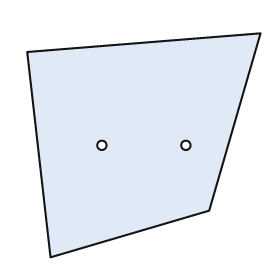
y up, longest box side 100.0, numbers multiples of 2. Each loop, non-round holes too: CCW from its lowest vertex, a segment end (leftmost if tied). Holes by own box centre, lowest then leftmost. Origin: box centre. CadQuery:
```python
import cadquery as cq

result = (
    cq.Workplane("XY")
    .moveTo(-40.0, -48.0)
    .lineTo(28.0, -28.0)
    .lineTo(50.0, 48.0)
    .lineTo(-50.0, 40.0)
    .close()
    .moveTo(-18.0, 0.0)
    .circle(2.0)
    .moveTo(18.0, 0.0)
    .circle(2.0)
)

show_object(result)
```